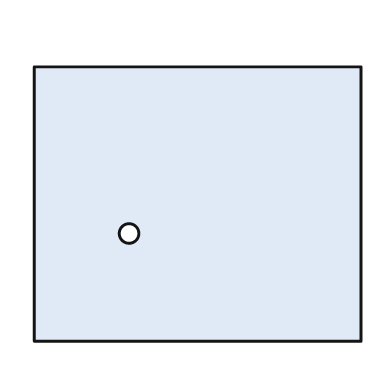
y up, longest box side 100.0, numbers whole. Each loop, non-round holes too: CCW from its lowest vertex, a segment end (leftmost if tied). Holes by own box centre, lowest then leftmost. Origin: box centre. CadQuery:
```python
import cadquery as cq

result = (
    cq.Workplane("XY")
    .moveTo(-50.0, -42.0)
    .lineTo(50.0, -42.0)
    .lineTo(50.0, 42.0)
    .lineTo(-50.0, 42.0)
    .close()
    .moveTo(-21.0, -9.0)
    .circle(3.0)
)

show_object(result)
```